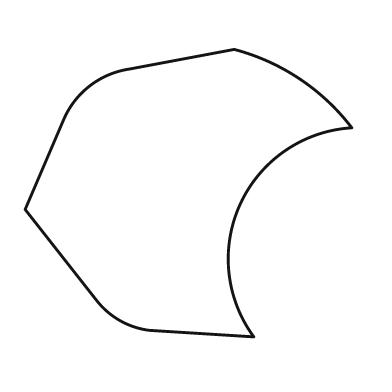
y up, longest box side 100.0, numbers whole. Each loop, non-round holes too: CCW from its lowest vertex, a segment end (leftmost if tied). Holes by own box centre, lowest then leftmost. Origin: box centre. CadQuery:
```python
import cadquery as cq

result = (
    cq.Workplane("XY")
    .moveTo(20.0, -44.0)
    .threePointArc((16.0, -3.0), (50.0, 20.0))
    .threePointArc((34.0, 35.0), (14.0, 44.0))
    .lineTo(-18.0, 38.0)
    .threePointArc((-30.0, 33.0), (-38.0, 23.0))
    .lineTo(-50.0, -5.0)
    .lineTo(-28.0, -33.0)
    .threePointArc((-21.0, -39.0), (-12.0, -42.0))
    .close()
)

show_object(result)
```